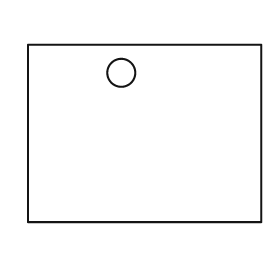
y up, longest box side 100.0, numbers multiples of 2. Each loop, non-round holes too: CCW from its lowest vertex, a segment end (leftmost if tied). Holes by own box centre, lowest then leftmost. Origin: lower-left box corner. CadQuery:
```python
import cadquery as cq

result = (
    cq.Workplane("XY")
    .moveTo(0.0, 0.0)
    .lineTo(100.0, 0.0)
    .lineTo(100.0, 76.0)
    .lineTo(0.0, 76.0)
    .close()
    .moveTo(40.0, 64.0)
    .circle(6.0)
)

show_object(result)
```